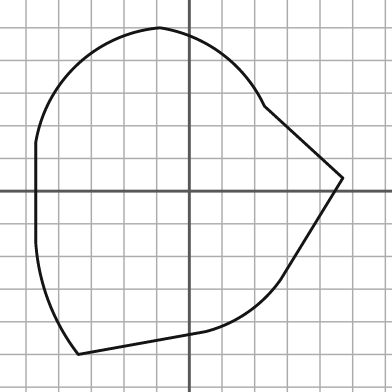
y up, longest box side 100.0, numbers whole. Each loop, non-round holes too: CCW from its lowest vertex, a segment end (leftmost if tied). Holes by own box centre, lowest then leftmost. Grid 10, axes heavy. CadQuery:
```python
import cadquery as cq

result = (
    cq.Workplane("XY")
    .moveTo(-34.0, -50.0)
    .lineTo(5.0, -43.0)
    .threePointArc((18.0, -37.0), (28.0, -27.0))
    .lineTo(47.0, 4.0)
    .lineTo(23.0, 26.0)
    .threePointArc((10.0, 42.0), (-9.0, 50.0))
    .threePointArc((-34.0, 39.0), (-47.0, 15.0))
    .lineTo(-47.0, -16.0)
    .threePointArc((-43.0, -34.0), (-34.0, -50.0))
    .close()
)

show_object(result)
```